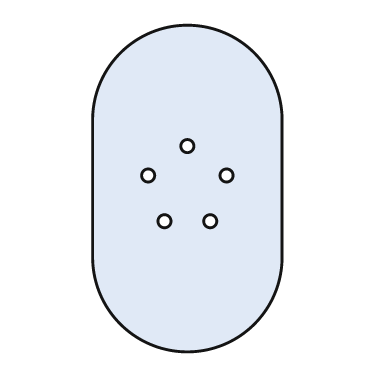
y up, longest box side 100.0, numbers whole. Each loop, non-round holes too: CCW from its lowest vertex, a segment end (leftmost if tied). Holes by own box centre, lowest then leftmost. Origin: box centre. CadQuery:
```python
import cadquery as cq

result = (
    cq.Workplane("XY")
    .moveTo(-29.0, -21.0)
    .threePointArc((0.0, -50.0), (29.0, -21.0))
    .lineTo(29.0, 21.0)
    .threePointArc((0.0, 50.0), (-29.0, 21.0))
    .close()
    .moveTo(-7.0, -10.0)
    .circle(2.0)
    .moveTo(7.0, -10.0)
    .circle(2.0)
    .moveTo(-12.0, 4.0)
    .circle(2.0)
    .moveTo(12.0, 4.0)
    .circle(2.0)
    .moveTo(0.0, 13.0)
    .circle(2.0)
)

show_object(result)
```